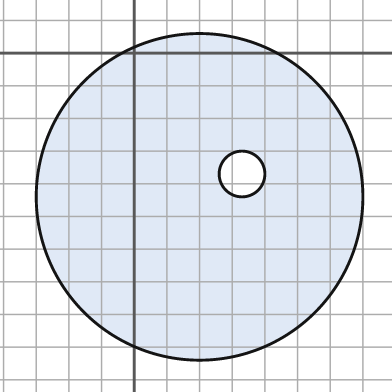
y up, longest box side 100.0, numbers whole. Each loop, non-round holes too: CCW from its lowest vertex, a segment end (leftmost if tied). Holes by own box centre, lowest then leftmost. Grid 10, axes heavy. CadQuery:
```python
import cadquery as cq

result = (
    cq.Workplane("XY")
    .moveTo(20.0, -44.0)
    .circle(50.0)
    .moveTo(33.0, -37.0)
    .circle(7.0)
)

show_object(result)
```